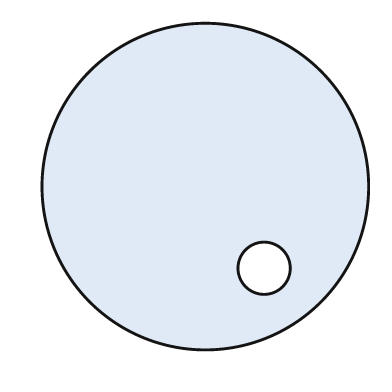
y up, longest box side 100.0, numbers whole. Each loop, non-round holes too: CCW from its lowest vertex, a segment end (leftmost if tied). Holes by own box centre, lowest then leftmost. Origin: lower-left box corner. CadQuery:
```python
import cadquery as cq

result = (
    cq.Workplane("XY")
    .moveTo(50.0, 50.0)
    .circle(50.0)
    .moveTo(68.0, 25.0)
    .circle(8.0)
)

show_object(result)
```